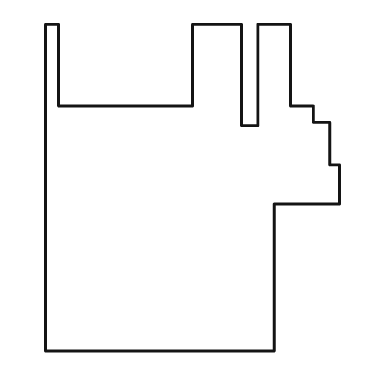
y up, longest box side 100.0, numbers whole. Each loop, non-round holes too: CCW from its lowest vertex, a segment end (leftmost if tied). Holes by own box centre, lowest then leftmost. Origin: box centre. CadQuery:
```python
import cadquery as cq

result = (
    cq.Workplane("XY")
    .moveTo(-45.0, -50.0)
    .lineTo(25.0, -50.0)
    .lineTo(25.0, -5.0)
    .lineTo(45.0, -5.0)
    .lineTo(45.0, 7.0)
    .lineTo(42.0, 7.0)
    .lineTo(42.0, 20.0)
    .lineTo(37.0, 20.0)
    .lineTo(37.0, 25.0)
    .lineTo(30.0, 25.0)
    .lineTo(30.0, 50.0)
    .lineTo(20.0, 50.0)
    .lineTo(20.0, 19.0)
    .lineTo(15.0, 19.0)
    .lineTo(15.0, 50.0)
    .lineTo(0.0, 50.0)
    .lineTo(0.0, 25.0)
    .lineTo(-41.0, 25.0)
    .lineTo(-41.0, 50.0)
    .lineTo(-45.0, 50.0)
    .close()
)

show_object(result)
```